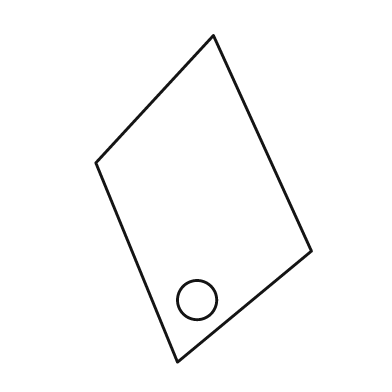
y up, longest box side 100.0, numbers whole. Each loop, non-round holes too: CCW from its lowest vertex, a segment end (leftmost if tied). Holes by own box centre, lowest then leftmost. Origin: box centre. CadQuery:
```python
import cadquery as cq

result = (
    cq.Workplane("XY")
    .moveTo(-8.0, -50.0)
    .lineTo(33.0, -16.0)
    .lineTo(3.0, 50.0)
    .lineTo(-33.0, 11.0)
    .close()
    .moveTo(-2.0, -31.0)
    .circle(6.0)
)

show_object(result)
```